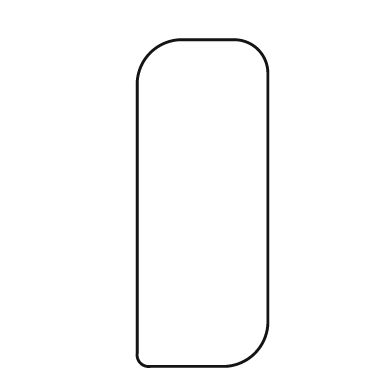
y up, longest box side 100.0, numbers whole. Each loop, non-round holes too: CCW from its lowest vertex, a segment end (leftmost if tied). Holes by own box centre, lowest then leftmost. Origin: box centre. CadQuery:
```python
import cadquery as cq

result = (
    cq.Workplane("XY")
    .moveTo(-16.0, -50.0)
    .lineTo(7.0, -50.0)
    .threePointArc((16.0, -46.0), (20.0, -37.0))
    .lineTo(20.0, 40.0)
    .threePointArc((17.0, 47.0), (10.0, 50.0))
    .lineTo(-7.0, 50.0)
    .threePointArc((-16.0, 46.0), (-20.0, 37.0))
    .lineTo(-20.0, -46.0)
    .threePointArc((-19.0, -49.0), (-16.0, -50.0))
    .close()
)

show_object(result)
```